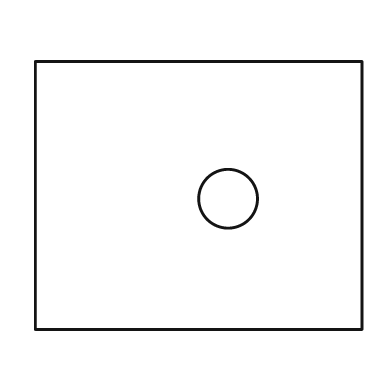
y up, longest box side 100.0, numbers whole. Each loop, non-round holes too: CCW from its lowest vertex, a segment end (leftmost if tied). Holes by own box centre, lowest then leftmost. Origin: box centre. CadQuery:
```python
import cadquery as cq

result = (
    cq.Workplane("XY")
    .moveTo(-50.0, -41.0)
    .lineTo(50.0, -41.0)
    .lineTo(50.0, 41.0)
    .lineTo(-50.0, 41.0)
    .close()
    .moveTo(9.0, -1.0)
    .circle(9.0)
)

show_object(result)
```